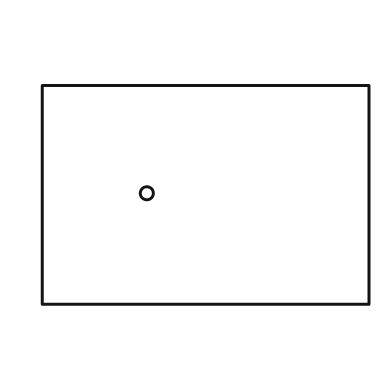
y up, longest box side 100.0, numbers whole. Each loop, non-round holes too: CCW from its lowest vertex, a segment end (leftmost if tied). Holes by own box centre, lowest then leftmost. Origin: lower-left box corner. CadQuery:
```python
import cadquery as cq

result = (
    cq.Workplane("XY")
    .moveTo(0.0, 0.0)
    .lineTo(100.0, 0.0)
    .lineTo(100.0, 67.0)
    .lineTo(0.0, 67.0)
    .close()
    .moveTo(32.0, 34.0)
    .circle(2.0)
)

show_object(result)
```